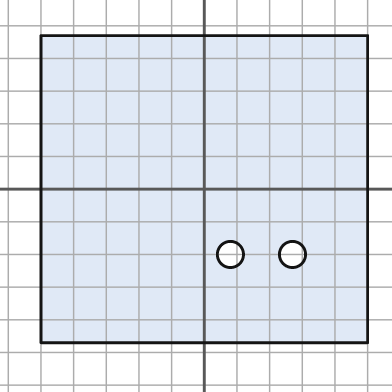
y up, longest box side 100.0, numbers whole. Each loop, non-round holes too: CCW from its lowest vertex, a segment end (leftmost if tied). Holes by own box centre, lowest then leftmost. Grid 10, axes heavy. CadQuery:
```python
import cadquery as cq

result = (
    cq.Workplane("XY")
    .moveTo(-50.0, -47.0)
    .lineTo(50.0, -47.0)
    .lineTo(50.0, 47.0)
    .lineTo(-50.0, 47.0)
    .close()
    .moveTo(8.0, -20.0)
    .circle(4.0)
    .moveTo(27.0, -20.0)
    .circle(4.0)
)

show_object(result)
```